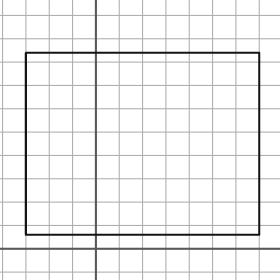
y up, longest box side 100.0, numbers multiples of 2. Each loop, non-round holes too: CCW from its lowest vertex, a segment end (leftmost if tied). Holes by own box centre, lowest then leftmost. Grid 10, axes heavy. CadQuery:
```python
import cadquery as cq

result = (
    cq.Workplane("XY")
    .moveTo(-30.0, 6.0)
    .lineTo(70.0, 6.0)
    .lineTo(70.0, 84.0)
    .lineTo(-30.0, 84.0)
    .close()
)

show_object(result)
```